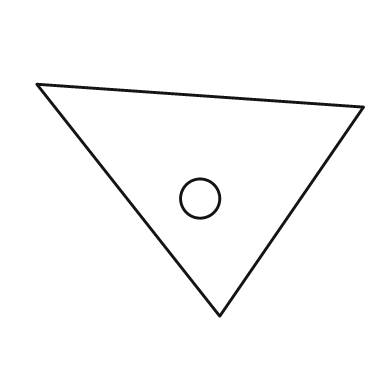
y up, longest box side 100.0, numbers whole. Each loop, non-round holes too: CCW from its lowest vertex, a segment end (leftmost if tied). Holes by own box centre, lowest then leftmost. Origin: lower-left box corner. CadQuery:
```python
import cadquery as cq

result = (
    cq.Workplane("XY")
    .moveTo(56.0, 0.0)
    .lineTo(100.0, 64.0)
    .lineTo(0.0, 71.0)
    .close()
    .moveTo(50.0, 36.0)
    .circle(6.0)
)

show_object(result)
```